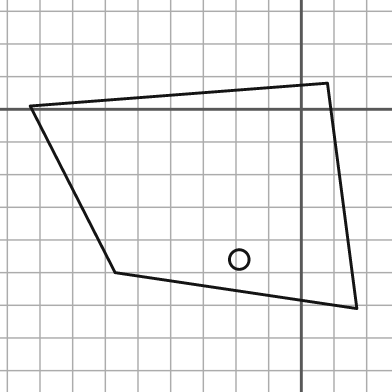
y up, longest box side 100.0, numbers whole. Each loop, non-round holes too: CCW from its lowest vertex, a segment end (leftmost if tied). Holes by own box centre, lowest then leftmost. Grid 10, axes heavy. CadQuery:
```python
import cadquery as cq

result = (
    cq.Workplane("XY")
    .moveTo(17.0, -61.0)
    .lineTo(8.0, 8.0)
    .lineTo(-83.0, 1.0)
    .lineTo(-57.0, -50.0)
    .close()
    .moveTo(-19.0, -46.0)
    .circle(3.0)
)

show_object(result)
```